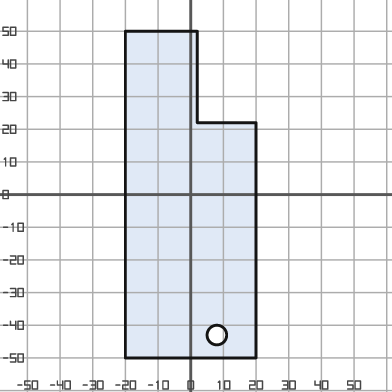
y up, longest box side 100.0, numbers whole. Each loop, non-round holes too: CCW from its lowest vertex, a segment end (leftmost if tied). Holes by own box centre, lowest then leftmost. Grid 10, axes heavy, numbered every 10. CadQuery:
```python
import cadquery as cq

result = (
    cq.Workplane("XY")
    .moveTo(-20.0, -50.0)
    .lineTo(20.0, -50.0)
    .lineTo(20.0, 22.0)
    .lineTo(2.0, 22.0)
    .lineTo(2.0, 50.0)
    .lineTo(-20.0, 50.0)
    .close()
    .moveTo(8.0, -43.0)
    .circle(3.0)
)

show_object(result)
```